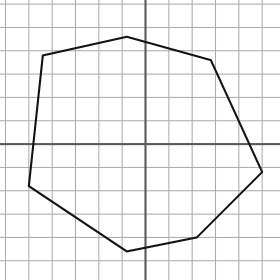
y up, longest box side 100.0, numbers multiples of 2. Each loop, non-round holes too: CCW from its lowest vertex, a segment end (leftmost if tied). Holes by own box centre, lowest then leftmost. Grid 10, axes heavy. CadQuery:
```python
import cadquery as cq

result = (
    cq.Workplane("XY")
    .moveTo(-8.0, -46.0)
    .lineTo(22.0, -40.0)
    .lineTo(50.0, -12.0)
    .lineTo(28.0, 36.0)
    .lineTo(-8.0, 46.0)
    .lineTo(-44.0, 38.0)
    .lineTo(-50.0, -18.0)
    .close()
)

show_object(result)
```